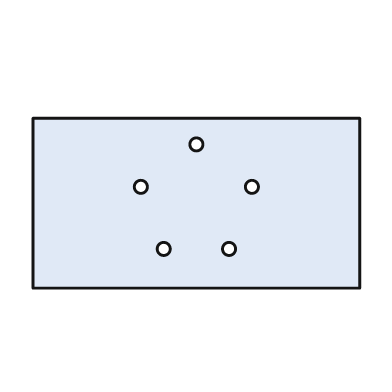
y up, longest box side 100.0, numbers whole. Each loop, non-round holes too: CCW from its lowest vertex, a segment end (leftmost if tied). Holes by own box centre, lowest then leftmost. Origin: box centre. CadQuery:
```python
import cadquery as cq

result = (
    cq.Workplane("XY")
    .moveTo(-50.0, -26.0)
    .lineTo(50.0, -26.0)
    .lineTo(50.0, 26.0)
    .lineTo(-50.0, 26.0)
    .close()
    .moveTo(-10.0, -14.0)
    .circle(2.0)
    .moveTo(10.0, -14.0)
    .circle(2.0)
    .moveTo(-17.0, 5.0)
    .circle(2.0)
    .moveTo(17.0, 5.0)
    .circle(2.0)
    .moveTo(0.0, 18.0)
    .circle(2.0)
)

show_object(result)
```